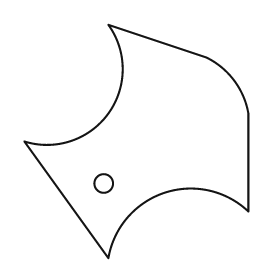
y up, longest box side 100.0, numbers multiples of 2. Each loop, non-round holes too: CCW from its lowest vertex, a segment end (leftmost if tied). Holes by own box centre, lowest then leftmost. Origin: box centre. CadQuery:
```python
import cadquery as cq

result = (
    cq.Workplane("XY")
    .moveTo(-12.0, -50.0)
    .threePointArc((12.0, -22.0), (48.0, -30.0))
    .lineTo(48.0, 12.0)
    .threePointArc((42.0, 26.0), (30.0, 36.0))
    .lineTo(-12.0, 50.0)
    .threePointArc((-12.0, 12.0), (-48.0, 0.0))
    .close()
    .moveTo(-14.0, -18.0)
    .circle(4.0)
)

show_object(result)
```